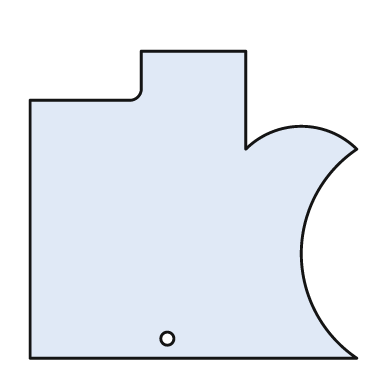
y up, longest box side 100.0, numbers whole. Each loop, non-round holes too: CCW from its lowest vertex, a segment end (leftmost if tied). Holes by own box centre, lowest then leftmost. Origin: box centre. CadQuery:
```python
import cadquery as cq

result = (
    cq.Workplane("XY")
    .moveTo(-50.0, -47.0)
    .lineTo(50.0, -47.0)
    .threePointArc((33.0, -15.0), (50.0, 17.0))
    .threePointArc((33.0, 24.0), (16.0, 17.0))
    .lineTo(16.0, 47.0)
    .lineTo(-16.0, 47.0)
    .lineTo(-16.0, 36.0)
    .threePointArc((-17.0, 33.0), (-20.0, 32.0))
    .lineTo(-50.0, 32.0)
    .close()
    .moveTo(-8.0, -41.0)
    .circle(2.0)
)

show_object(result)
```